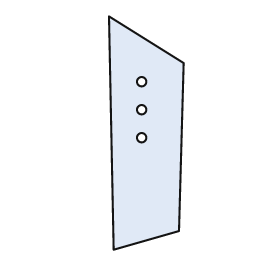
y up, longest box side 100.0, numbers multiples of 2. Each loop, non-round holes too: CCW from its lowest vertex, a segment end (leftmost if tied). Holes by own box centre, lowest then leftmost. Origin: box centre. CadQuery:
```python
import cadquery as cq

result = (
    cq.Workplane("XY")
    .moveTo(-14.0, -50.0)
    .lineTo(14.0, -42.0)
    .lineTo(16.0, 30.0)
    .lineTo(-16.0, 50.0)
    .close()
    .moveTo(-2.0, -2.0)
    .circle(2.0)
    .moveTo(-2.0, 10.0)
    .circle(2.0)
    .moveTo(-2.0, 22.0)
    .circle(2.0)
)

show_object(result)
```